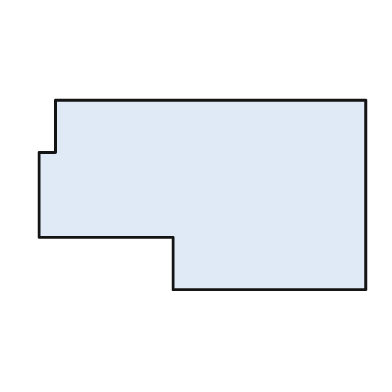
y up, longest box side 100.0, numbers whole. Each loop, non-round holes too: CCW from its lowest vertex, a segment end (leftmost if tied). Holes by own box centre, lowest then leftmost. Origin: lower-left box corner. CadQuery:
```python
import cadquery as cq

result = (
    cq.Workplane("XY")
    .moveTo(41.0, 0.0)
    .lineTo(100.0, 0.0)
    .lineTo(100.0, 58.0)
    .lineTo(5.0, 58.0)
    .lineTo(5.0, 42.0)
    .lineTo(0.0, 42.0)
    .lineTo(0.0, 16.0)
    .lineTo(41.0, 16.0)
    .close()
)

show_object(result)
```